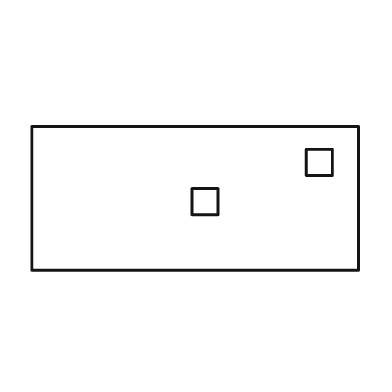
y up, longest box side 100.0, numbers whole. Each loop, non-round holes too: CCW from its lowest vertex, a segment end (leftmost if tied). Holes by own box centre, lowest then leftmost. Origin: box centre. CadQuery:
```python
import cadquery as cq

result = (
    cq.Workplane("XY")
    .moveTo(-50.0, -22.0)
    .lineTo(50.0, -22.0)
    .lineTo(50.0, 22.0)
    .lineTo(-50.0, 22.0)
    .close()
    .moveTo(-1.0, -5.0)
    .lineTo(7.0, -5.0)
    .lineTo(7.0, 3.0)
    .lineTo(-1.0, 3.0)
    .close()
    .moveTo(34.0, 7.0)
    .lineTo(42.0, 7.0)
    .lineTo(42.0, 15.0)
    .lineTo(34.0, 15.0)
    .close()
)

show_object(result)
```